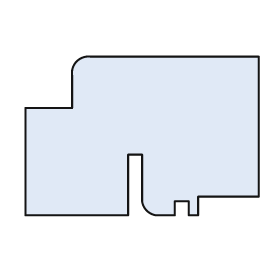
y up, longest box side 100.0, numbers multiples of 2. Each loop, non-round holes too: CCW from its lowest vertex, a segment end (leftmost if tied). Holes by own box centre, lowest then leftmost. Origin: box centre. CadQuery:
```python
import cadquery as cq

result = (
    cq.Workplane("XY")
    .moveTo(-50.0, -34.0)
    .lineTo(-6.0, -34.0)
    .lineTo(-6.0, -8.0)
    .lineTo(0.0, -8.0)
    .lineTo(0.0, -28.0)
    .threePointArc((2.0, -32.0), (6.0, -34.0))
    .lineTo(14.0, -34.0)
    .lineTo(14.0, -28.0)
    .lineTo(20.0, -28.0)
    .lineTo(20.0, -34.0)
    .lineTo(24.0, -34.0)
    .lineTo(24.0, -26.0)
    .lineTo(50.0, -26.0)
    .lineTo(50.0, 34.0)
    .lineTo(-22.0, 34.0)
    .threePointArc((-28.0, 32.0), (-30.0, 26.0))
    .lineTo(-30.0, 12.0)
    .lineTo(-50.0, 12.0)
    .close()
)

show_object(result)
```